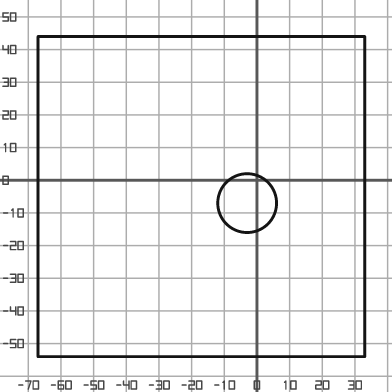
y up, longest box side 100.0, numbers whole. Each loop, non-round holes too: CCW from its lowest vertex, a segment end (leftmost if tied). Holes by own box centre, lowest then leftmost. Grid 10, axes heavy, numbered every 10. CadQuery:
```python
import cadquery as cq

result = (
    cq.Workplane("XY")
    .moveTo(-67.0, -54.0)
    .lineTo(33.0, -54.0)
    .lineTo(33.0, 44.0)
    .lineTo(-67.0, 44.0)
    .close()
    .moveTo(-3.0, -7.0)
    .circle(9.0)
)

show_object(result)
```